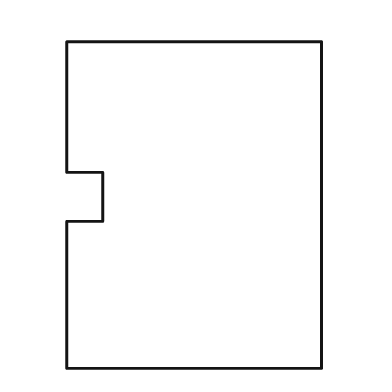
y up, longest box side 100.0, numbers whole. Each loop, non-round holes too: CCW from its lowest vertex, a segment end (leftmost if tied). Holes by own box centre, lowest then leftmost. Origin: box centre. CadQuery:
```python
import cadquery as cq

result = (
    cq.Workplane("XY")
    .moveTo(-39.0, -50.0)
    .lineTo(39.0, -50.0)
    .lineTo(39.0, 50.0)
    .lineTo(-39.0, 50.0)
    .lineTo(-39.0, 10.0)
    .lineTo(-28.0, 10.0)
    .lineTo(-28.0, -5.0)
    .lineTo(-39.0, -5.0)
    .close()
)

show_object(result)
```